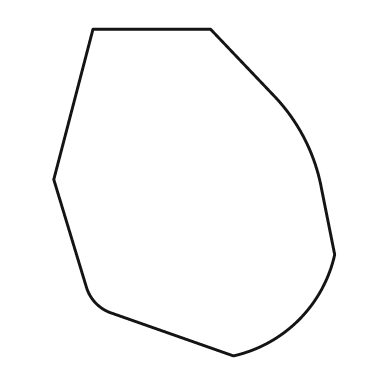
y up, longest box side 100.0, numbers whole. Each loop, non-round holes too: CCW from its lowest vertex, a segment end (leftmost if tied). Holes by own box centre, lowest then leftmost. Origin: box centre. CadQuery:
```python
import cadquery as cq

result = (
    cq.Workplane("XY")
    .moveTo(12.0, -50.0)
    .threePointArc((32.0, -39.0), (43.0, -19.0))
    .lineTo(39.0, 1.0)
    .threePointArc((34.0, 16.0), (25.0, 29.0))
    .lineTo(5.0, 50.0)
    .lineTo(-31.0, 50.0)
    .lineTo(-43.0, 4.0)
    .lineTo(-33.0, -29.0)
    .threePointArc((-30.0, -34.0), (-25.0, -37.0))
    .close()
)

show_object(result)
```